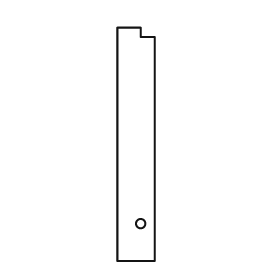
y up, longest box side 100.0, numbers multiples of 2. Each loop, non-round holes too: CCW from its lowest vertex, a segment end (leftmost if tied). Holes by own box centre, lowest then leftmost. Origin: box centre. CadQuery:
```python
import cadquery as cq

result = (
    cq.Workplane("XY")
    .moveTo(-8.0, -50.0)
    .lineTo(8.0, -50.0)
    .lineTo(8.0, 46.0)
    .lineTo(2.0, 46.0)
    .lineTo(2.0, 50.0)
    .lineTo(-8.0, 50.0)
    .close()
    .moveTo(2.0, -34.0)
    .circle(2.0)
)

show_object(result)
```